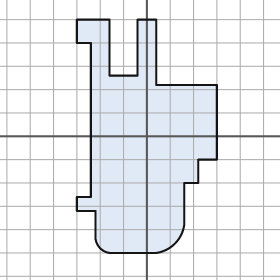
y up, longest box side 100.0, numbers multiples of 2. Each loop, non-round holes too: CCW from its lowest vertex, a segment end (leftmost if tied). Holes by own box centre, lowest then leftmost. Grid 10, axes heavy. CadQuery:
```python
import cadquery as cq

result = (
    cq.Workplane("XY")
    .moveTo(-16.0, -50.0)
    .lineTo(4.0, -50.0)
    .threePointArc((12.0, -46.0), (16.0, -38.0))
    .lineTo(16.0, -20.0)
    .lineTo(22.0, -20.0)
    .lineTo(22.0, -10.0)
    .lineTo(30.0, -10.0)
    .lineTo(30.0, 22.0)
    .lineTo(4.0, 22.0)
    .lineTo(4.0, 50.0)
    .lineTo(-4.0, 50.0)
    .lineTo(-4.0, 26.0)
    .lineTo(-16.0, 26.0)
    .lineTo(-16.0, 50.0)
    .lineTo(-30.0, 50.0)
    .lineTo(-30.0, 40.0)
    .lineTo(-24.0, 40.0)
    .lineTo(-24.0, -26.0)
    .lineTo(-30.0, -26.0)
    .lineTo(-30.0, -32.0)
    .lineTo(-22.0, -32.0)
    .lineTo(-22.0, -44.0)
    .threePointArc((-20.0, -48.0), (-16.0, -50.0))
    .close()
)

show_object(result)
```